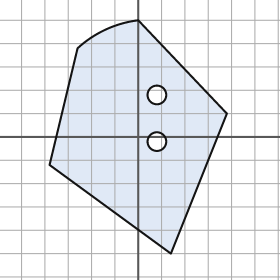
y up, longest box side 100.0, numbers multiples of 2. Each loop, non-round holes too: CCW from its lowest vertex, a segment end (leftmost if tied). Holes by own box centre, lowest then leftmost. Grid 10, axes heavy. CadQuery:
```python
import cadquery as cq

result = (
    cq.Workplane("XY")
    .moveTo(14.0, -50.0)
    .lineTo(38.0, 10.0)
    .lineTo(0.0, 50.0)
    .threePointArc((-14.0, 46.0), (-26.0, 38.0))
    .lineTo(-38.0, -12.0)
    .close()
    .moveTo(8.0, -2.0)
    .circle(4.0)
    .moveTo(8.0, 18.0)
    .circle(4.0)
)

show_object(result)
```